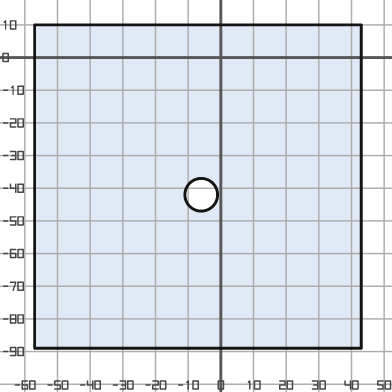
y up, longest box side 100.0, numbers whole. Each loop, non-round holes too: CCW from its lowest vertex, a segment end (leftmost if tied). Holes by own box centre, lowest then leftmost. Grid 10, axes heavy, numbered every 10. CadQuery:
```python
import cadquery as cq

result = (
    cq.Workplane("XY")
    .moveTo(-57.0, -89.0)
    .lineTo(43.0, -89.0)
    .lineTo(43.0, 10.0)
    .lineTo(-57.0, 10.0)
    .close()
    .moveTo(-6.0, -42.0)
    .circle(5.0)
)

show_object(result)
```